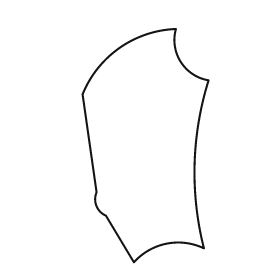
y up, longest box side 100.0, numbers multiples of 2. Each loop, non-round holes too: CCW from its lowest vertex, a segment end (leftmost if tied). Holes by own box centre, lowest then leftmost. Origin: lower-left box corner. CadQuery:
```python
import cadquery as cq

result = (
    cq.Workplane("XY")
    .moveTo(22.0, 0.0)
    .threePointArc((36.0, 8.0), (52.0, 6.0))
    .threePointArc((48.0, 42.0), (54.0, 78.0))
    .threePointArc((42.0, 86.0), (40.0, 100.0))
    .threePointArc((16.0, 92.0), (0.0, 72.0))
    .lineTo(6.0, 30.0)
    .threePointArc((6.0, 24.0), (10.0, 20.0))
    .close()
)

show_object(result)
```